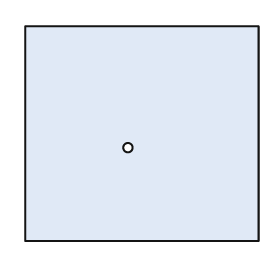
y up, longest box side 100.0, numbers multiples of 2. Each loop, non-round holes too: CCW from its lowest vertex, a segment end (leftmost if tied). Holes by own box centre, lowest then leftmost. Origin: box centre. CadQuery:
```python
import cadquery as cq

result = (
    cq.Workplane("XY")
    .moveTo(-50.0, -46.0)
    .lineTo(50.0, -46.0)
    .lineTo(50.0, 46.0)
    .lineTo(-50.0, 46.0)
    .close()
    .moveTo(-6.0, -6.0)
    .circle(2.0)
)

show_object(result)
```